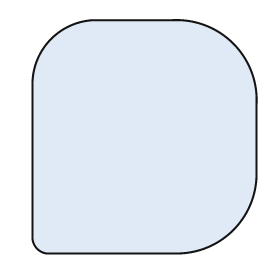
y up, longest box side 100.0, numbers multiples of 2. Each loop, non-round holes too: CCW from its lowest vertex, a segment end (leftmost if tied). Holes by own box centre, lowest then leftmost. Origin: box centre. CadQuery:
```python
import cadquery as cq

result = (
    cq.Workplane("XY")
    .moveTo(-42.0, -50.0)
    .lineTo(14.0, -50.0)
    .threePointArc((38.0, -40.0), (48.0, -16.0))
    .lineTo(48.0, 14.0)
    .threePointArc((38.0, 40.0), (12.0, 50.0))
    .lineTo(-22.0, 50.0)
    .threePointArc((-40.0, 42.0), (-48.0, 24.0))
    .lineTo(-48.0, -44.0)
    .threePointArc((-46.0, -48.0), (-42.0, -50.0))
    .close()
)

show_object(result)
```